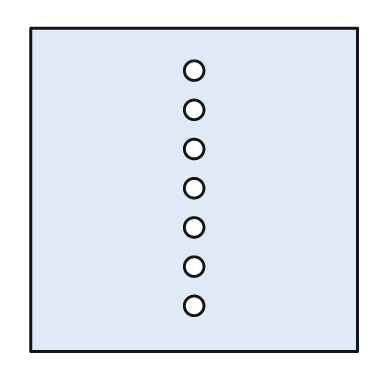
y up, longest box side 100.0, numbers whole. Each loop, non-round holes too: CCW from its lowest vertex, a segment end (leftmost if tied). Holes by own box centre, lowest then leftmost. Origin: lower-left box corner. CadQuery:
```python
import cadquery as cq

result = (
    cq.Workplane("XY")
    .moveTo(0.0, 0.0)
    .lineTo(100.0, 0.0)
    .lineTo(100.0, 99.0)
    .lineTo(0.0, 99.0)
    .close()
    .moveTo(50.0, 14.0)
    .circle(3.0)
    .moveTo(50.0, 26.0)
    .circle(3.0)
    .moveTo(50.0, 38.0)
    .circle(3.0)
    .moveTo(50.0, 50.0)
    .circle(3.0)
    .moveTo(50.0, 62.0)
    .circle(3.0)
    .moveTo(50.0, 74.0)
    .circle(3.0)
    .moveTo(50.0, 86.0)
    .circle(3.0)
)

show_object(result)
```